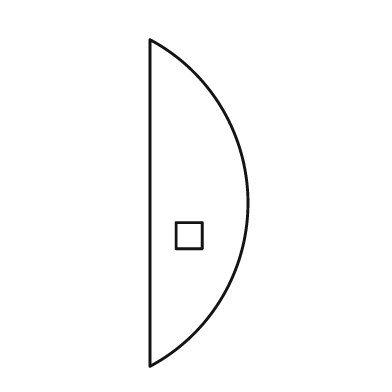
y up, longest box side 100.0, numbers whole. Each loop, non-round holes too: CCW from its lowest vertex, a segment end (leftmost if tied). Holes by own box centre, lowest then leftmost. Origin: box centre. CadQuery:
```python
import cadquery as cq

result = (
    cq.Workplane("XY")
    .moveTo(-15.0, -50.0)
    .threePointArc((15.0, 0.0), (-15.0, 50.0))
    .close()
    .moveTo(-7.0, -14.0)
    .lineTo(1.0, -14.0)
    .lineTo(1.0, -6.0)
    .lineTo(-7.0, -6.0)
    .close()
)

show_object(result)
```